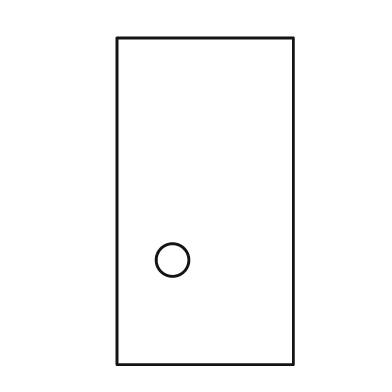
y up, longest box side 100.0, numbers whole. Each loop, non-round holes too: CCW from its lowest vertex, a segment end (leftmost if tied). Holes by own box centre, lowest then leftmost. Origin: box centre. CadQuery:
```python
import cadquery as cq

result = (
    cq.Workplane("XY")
    .moveTo(-27.0, -50.0)
    .lineTo(27.0, -50.0)
    .lineTo(27.0, 50.0)
    .lineTo(-27.0, 50.0)
    .close()
    .moveTo(-10.0, -18.0)
    .circle(5.0)
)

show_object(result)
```